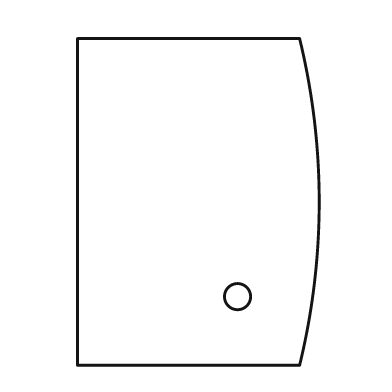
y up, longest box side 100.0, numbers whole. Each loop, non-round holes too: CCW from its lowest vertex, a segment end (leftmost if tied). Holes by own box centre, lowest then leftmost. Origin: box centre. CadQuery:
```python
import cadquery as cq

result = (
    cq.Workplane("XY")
    .moveTo(-37.0, -50.0)
    .lineTo(31.0, -50.0)
    .threePointArc((37.0, 0.0), (31.0, 50.0))
    .lineTo(-37.0, 50.0)
    .close()
    .moveTo(12.0, -29.0)
    .circle(4.0)
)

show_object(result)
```